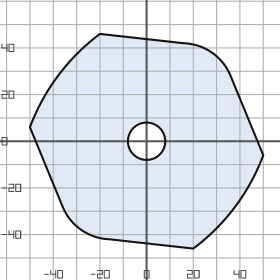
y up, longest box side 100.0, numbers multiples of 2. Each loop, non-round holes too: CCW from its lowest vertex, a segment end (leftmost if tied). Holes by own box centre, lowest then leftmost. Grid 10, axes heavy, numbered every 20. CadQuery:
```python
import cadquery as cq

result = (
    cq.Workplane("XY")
    .moveTo(20.0, -46.0)
    .threePointArc((38.0, -28.0), (50.0, -6.0))
    .lineTo(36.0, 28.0)
    .threePointArc((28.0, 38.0), (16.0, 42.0))
    .lineTo(-20.0, 46.0)
    .threePointArc((-38.0, 28.0), (-50.0, 6.0))
    .lineTo(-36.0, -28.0)
    .threePointArc((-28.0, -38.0), (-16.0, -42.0))
    .close()
    .moveTo(0.0, 0.0)
    .circle(8.0)
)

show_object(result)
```